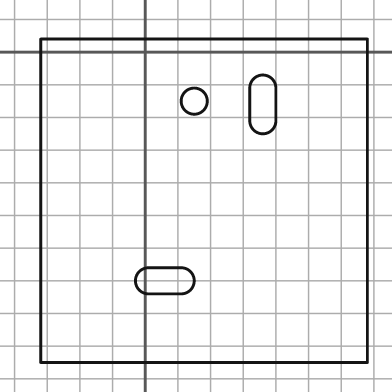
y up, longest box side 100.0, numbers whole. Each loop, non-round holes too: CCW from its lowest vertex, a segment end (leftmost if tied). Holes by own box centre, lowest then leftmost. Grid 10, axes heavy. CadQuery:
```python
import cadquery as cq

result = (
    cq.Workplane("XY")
    .moveTo(-32.0, -95.0)
    .lineTo(68.0, -95.0)
    .lineTo(68.0, 4.0)
    .lineTo(-32.0, 4.0)
    .close()
    .moveTo(1.0, -74.0)
    .lineTo(11.0, -74.0)
    .threePointArc((15.0, -70.0), (11.0, -66.0))
    .lineTo(1.0, -66.0)
    .threePointArc((-3.0, -70.0), (1.0, -74.0))
    .close()
    .moveTo(32.0, -21.0)
    .threePointArc((36.0, -25.0), (40.0, -21.0))
    .lineTo(40.0, -11.0)
    .threePointArc((36.0, -7.0), (32.0, -11.0))
    .close()
    .moveTo(15.0, -15.0)
    .circle(4.0)
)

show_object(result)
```